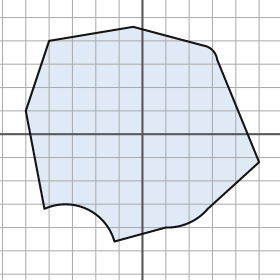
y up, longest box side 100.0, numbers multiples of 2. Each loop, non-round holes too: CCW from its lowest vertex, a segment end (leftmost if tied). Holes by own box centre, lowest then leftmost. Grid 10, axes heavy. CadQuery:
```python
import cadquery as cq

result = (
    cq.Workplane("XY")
    .moveTo(-12.0, -46.0)
    .lineTo(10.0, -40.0)
    .threePointArc((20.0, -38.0), (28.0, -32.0))
    .lineTo(50.0, -12.0)
    .lineTo(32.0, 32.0)
    .threePointArc((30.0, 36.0), (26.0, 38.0))
    .lineTo(-4.0, 46.0)
    .lineTo(-40.0, 40.0)
    .lineTo(-50.0, 10.0)
    .lineTo(-42.0, -32.0)
    .threePointArc((-24.0, -32.0), (-12.0, -46.0))
    .close()
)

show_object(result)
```